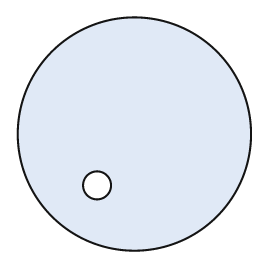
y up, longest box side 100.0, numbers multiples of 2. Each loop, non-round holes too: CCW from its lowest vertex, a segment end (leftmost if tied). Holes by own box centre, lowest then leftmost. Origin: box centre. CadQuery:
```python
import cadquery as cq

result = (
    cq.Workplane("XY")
    .moveTo(0.0, 0.0)
    .circle(50.0)
    .moveTo(-16.0, -22.0)
    .circle(6.0)
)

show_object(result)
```